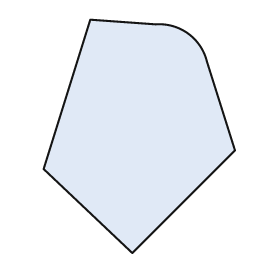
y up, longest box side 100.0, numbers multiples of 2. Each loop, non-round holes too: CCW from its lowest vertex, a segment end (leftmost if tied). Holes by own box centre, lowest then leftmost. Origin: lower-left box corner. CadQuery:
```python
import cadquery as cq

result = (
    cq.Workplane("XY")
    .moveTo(38.0, 0.0)
    .lineTo(82.0, 44.0)
    .lineTo(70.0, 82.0)
    .threePointArc((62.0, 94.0), (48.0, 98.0))
    .lineTo(20.0, 100.0)
    .lineTo(0.0, 36.0)
    .close()
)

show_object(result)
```